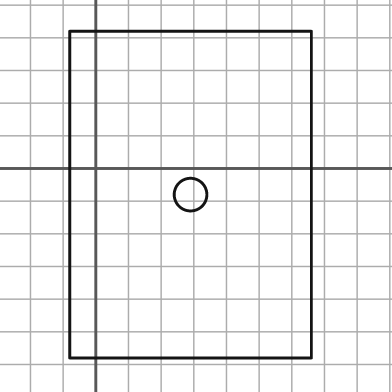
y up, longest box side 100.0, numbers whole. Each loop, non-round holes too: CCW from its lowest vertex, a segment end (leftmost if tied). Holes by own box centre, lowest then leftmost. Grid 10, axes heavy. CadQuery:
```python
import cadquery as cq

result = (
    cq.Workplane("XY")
    .moveTo(-8.0, -58.0)
    .lineTo(66.0, -58.0)
    .lineTo(66.0, 42.0)
    .lineTo(-8.0, 42.0)
    .close()
    .moveTo(29.0, -8.0)
    .circle(5.0)
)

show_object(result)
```